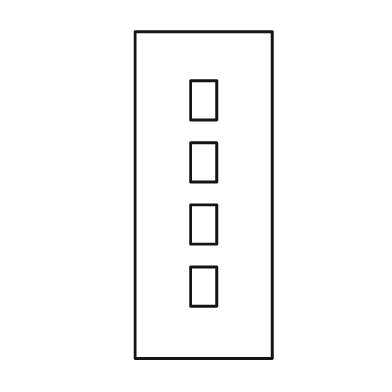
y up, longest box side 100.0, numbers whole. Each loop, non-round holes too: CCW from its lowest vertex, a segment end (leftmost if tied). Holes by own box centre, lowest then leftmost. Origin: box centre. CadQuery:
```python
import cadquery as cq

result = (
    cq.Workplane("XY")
    .moveTo(-21.0, -50.0)
    .lineTo(21.0, -50.0)
    .lineTo(21.0, 50.0)
    .lineTo(-21.0, 50.0)
    .close()
    .moveTo(-4.0, -34.0)
    .lineTo(4.0, -34.0)
    .lineTo(4.0, -22.0)
    .lineTo(-4.0, -22.0)
    .close()
    .moveTo(-4.0, -15.0)
    .lineTo(4.0, -15.0)
    .lineTo(4.0, -3.0)
    .lineTo(-4.0, -3.0)
    .close()
    .moveTo(-4.0, 4.0)
    .lineTo(4.0, 4.0)
    .lineTo(4.0, 16.0)
    .lineTo(-4.0, 16.0)
    .close()
    .moveTo(-4.0, 23.0)
    .lineTo(4.0, 23.0)
    .lineTo(4.0, 35.0)
    .lineTo(-4.0, 35.0)
    .close()
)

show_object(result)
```